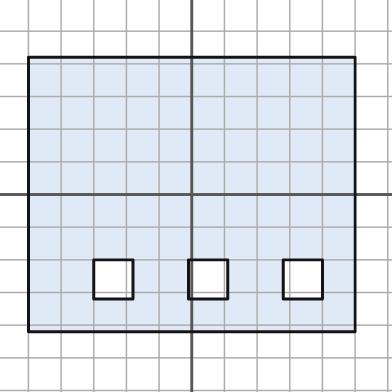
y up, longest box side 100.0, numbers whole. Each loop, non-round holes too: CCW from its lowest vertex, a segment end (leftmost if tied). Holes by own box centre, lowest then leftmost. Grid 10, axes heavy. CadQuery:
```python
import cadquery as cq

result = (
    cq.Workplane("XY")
    .moveTo(-50.0, -42.0)
    .lineTo(50.0, -42.0)
    .lineTo(50.0, 42.0)
    .lineTo(-50.0, 42.0)
    .close()
    .moveTo(-30.0, -32.0)
    .lineTo(-18.0, -32.0)
    .lineTo(-18.0, -20.0)
    .lineTo(-30.0, -20.0)
    .close()
    .moveTo(-1.0, -32.0)
    .lineTo(11.0, -32.0)
    .lineTo(11.0, -20.0)
    .lineTo(-1.0, -20.0)
    .close()
    .moveTo(28.0, -32.0)
    .lineTo(40.0, -32.0)
    .lineTo(40.0, -20.0)
    .lineTo(28.0, -20.0)
    .close()
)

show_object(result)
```